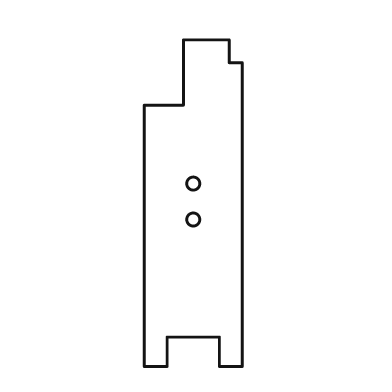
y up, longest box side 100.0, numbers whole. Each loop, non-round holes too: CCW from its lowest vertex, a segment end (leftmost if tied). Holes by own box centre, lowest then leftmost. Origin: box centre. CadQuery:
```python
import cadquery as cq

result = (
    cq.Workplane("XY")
    .moveTo(-15.0, -50.0)
    .lineTo(-8.0, -50.0)
    .lineTo(-8.0, -41.0)
    .lineTo(8.0, -41.0)
    .lineTo(8.0, -50.0)
    .lineTo(15.0, -50.0)
    .lineTo(15.0, 43.0)
    .lineTo(11.0, 43.0)
    .lineTo(11.0, 50.0)
    .lineTo(-3.0, 50.0)
    .lineTo(-3.0, 30.0)
    .lineTo(-15.0, 30.0)
    .close()
    .moveTo(0.0, -5.0)
    .circle(2.0)
    .moveTo(0.0, 6.0)
    .circle(2.0)
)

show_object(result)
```